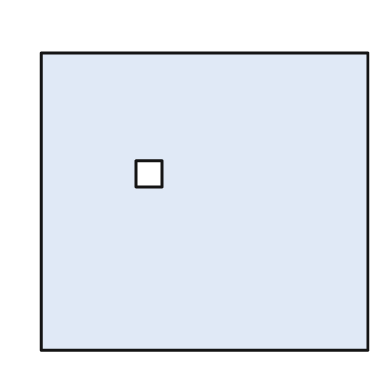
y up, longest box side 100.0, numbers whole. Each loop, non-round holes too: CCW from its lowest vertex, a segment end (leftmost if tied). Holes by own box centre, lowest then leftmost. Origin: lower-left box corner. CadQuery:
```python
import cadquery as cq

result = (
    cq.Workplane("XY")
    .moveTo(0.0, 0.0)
    .lineTo(100.0, 0.0)
    .lineTo(100.0, 91.0)
    .lineTo(0.0, 91.0)
    .close()
    .moveTo(29.0, 50.0)
    .lineTo(37.0, 50.0)
    .lineTo(37.0, 58.0)
    .lineTo(29.0, 58.0)
    .close()
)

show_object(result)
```